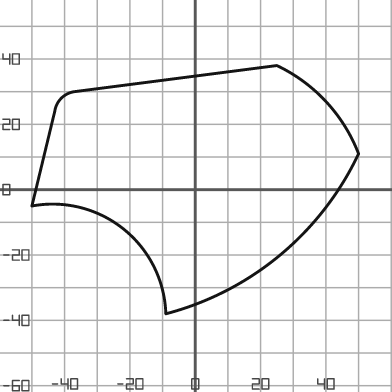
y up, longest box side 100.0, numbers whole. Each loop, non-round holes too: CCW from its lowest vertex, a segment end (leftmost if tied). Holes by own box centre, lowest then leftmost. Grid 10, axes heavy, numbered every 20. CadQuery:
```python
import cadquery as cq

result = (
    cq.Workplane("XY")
    .moveTo(-9.0, -38.0)
    .threePointArc((26.0, -20.0), (50.0, 11.0))
    .threePointArc((40.0, 27.0), (25.0, 38.0))
    .lineTo(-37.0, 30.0)
    .threePointArc((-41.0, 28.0), (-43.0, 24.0))
    .lineTo(-50.0, -5.0)
    .threePointArc((-22.0, -12.0), (-9.0, -38.0))
    .close()
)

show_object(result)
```